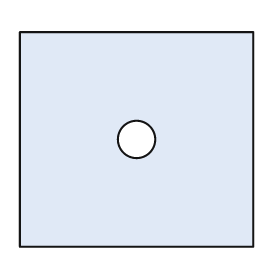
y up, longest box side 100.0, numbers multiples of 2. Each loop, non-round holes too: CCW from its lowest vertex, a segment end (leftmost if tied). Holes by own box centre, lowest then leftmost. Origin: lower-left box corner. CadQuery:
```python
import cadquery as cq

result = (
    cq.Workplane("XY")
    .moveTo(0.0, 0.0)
    .lineTo(100.0, 0.0)
    .lineTo(100.0, 92.0)
    .lineTo(0.0, 92.0)
    .close()
    .moveTo(50.0, 46.0)
    .circle(8.0)
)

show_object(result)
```